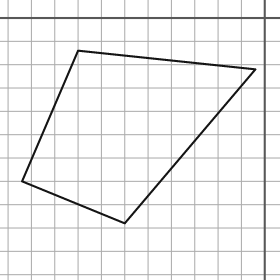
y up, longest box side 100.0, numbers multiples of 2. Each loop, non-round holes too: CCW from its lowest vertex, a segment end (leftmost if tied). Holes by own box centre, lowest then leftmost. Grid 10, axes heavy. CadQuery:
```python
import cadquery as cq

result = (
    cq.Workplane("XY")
    .moveTo(-60.0, -88.0)
    .lineTo(-4.0, -22.0)
    .lineTo(-80.0, -14.0)
    .lineTo(-104.0, -70.0)
    .close()
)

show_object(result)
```